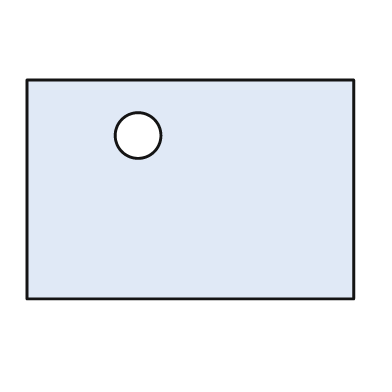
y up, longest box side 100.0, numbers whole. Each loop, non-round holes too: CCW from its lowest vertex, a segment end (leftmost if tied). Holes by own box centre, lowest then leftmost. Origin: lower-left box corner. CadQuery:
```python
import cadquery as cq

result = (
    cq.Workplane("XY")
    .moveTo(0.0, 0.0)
    .lineTo(100.0, 0.0)
    .lineTo(100.0, 67.0)
    .lineTo(0.0, 67.0)
    .close()
    .moveTo(34.0, 50.0)
    .circle(7.0)
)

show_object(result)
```